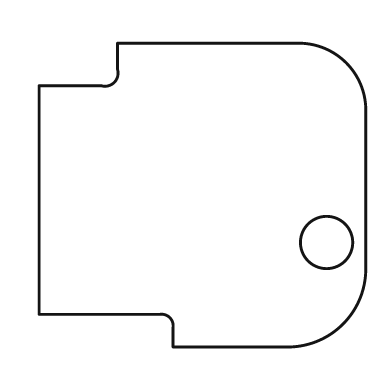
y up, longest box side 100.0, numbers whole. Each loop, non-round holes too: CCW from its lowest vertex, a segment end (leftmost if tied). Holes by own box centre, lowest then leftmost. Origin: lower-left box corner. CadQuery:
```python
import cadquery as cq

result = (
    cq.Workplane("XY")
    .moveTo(41.0, 0.0)
    .lineTo(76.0, 0.0)
    .threePointArc((93.0, 7.0), (100.0, 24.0))
    .lineTo(100.0, 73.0)
    .threePointArc((94.0, 87.0), (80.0, 93.0))
    .lineTo(24.0, 93.0)
    .lineTo(24.0, 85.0)
    .threePointArc((23.0, 81.0), (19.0, 80.0))
    .lineTo(0.0, 80.0)
    .lineTo(0.0, 10.0)
    .lineTo(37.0, 10.0)
    .threePointArc((40.0, 9.0), (41.0, 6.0))
    .close()
    .moveTo(88.0, 32.0)
    .circle(8.0)
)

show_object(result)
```